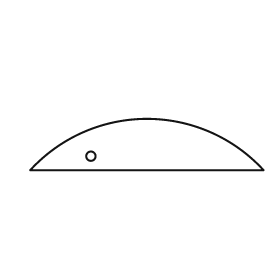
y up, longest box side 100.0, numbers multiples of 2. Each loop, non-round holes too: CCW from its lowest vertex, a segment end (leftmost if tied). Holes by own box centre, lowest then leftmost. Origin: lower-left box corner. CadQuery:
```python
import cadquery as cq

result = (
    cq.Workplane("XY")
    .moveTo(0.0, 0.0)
    .lineTo(100.0, 0.0)
    .threePointArc((50.0, 22.0), (0.0, 0.0))
    .close()
    .moveTo(26.0, 6.0)
    .circle(2.0)
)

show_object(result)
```